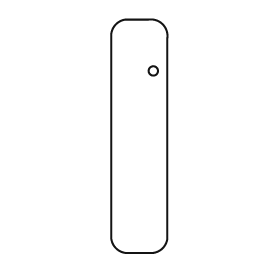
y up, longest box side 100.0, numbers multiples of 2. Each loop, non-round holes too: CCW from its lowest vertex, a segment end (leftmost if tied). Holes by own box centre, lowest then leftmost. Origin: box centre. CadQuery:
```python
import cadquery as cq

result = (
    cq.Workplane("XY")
    .moveTo(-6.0, -50.0)
    .lineTo(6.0, -50.0)
    .threePointArc((10.0, -48.0), (12.0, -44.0))
    .lineTo(12.0, 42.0)
    .threePointArc((10.0, 48.0), (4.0, 50.0))
    .lineTo(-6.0, 50.0)
    .threePointArc((-10.0, 48.0), (-12.0, 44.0))
    .lineTo(-12.0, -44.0)
    .threePointArc((-10.0, -48.0), (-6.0, -50.0))
    .close()
    .moveTo(6.0, 28.0)
    .circle(2.0)
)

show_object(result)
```